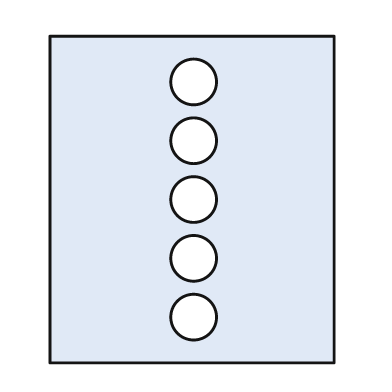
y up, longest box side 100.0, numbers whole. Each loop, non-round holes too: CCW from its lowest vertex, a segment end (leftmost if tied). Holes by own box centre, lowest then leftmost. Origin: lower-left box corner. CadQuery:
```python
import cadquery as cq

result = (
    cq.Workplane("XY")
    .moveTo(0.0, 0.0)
    .lineTo(87.0, 0.0)
    .lineTo(87.0, 100.0)
    .lineTo(0.0, 100.0)
    .close()
    .moveTo(44.0, 14.0)
    .circle(7.0)
    .moveTo(44.0, 32.0)
    .circle(7.0)
    .moveTo(44.0, 50.0)
    .circle(7.0)
    .moveTo(44.0, 68.0)
    .circle(7.0)
    .moveTo(44.0, 86.0)
    .circle(7.0)
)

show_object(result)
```